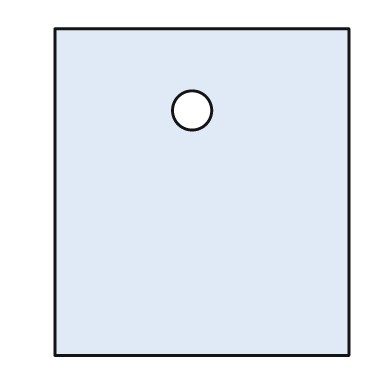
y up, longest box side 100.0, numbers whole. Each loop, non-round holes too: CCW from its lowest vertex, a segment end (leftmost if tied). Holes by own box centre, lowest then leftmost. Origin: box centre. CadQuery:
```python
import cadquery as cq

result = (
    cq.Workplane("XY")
    .moveTo(-45.0, -50.0)
    .lineTo(45.0, -50.0)
    .lineTo(45.0, 50.0)
    .lineTo(-45.0, 50.0)
    .close()
    .moveTo(-3.0, 25.0)
    .circle(6.0)
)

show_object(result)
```